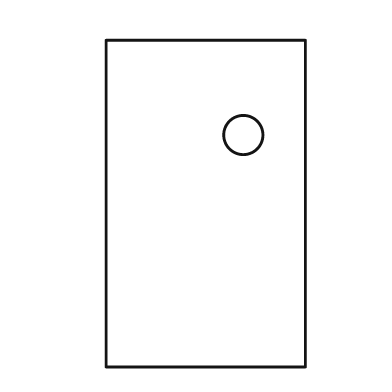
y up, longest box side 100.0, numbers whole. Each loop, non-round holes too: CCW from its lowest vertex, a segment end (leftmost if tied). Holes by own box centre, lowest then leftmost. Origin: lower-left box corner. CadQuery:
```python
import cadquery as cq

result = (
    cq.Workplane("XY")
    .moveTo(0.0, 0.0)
    .lineTo(61.0, 0.0)
    .lineTo(61.0, 100.0)
    .lineTo(0.0, 100.0)
    .close()
    .moveTo(42.0, 71.0)
    .circle(6.0)
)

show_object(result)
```